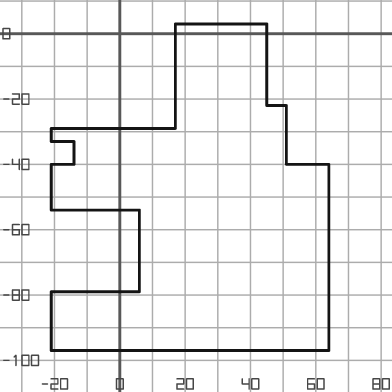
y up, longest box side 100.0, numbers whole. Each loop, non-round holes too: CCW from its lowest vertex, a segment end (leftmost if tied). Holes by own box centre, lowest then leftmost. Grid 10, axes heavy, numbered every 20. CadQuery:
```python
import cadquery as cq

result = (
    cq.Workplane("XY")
    .moveTo(-21.0, -97.0)
    .lineTo(64.0, -97.0)
    .lineTo(64.0, -40.0)
    .lineTo(51.0, -40.0)
    .lineTo(51.0, -22.0)
    .lineTo(45.0, -22.0)
    .lineTo(45.0, 3.0)
    .lineTo(17.0, 3.0)
    .lineTo(17.0, -29.0)
    .lineTo(-21.0, -29.0)
    .lineTo(-21.0, -33.0)
    .lineTo(-14.0, -33.0)
    .lineTo(-14.0, -40.0)
    .lineTo(-21.0, -40.0)
    .lineTo(-21.0, -54.0)
    .lineTo(6.0, -54.0)
    .lineTo(6.0, -79.0)
    .lineTo(-21.0, -79.0)
    .close()
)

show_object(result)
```